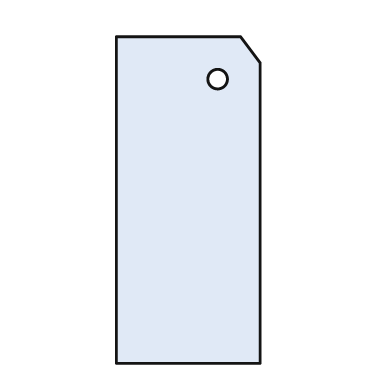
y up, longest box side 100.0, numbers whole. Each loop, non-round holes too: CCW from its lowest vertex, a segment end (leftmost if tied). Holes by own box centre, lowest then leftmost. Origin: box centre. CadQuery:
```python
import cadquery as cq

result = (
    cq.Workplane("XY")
    .moveTo(-22.0, -50.0)
    .lineTo(22.0, -50.0)
    .lineTo(22.0, 42.0)
    .lineTo(16.0, 50.0)
    .lineTo(-22.0, 50.0)
    .close()
    .moveTo(9.0, 37.0)
    .circle(3.0)
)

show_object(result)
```